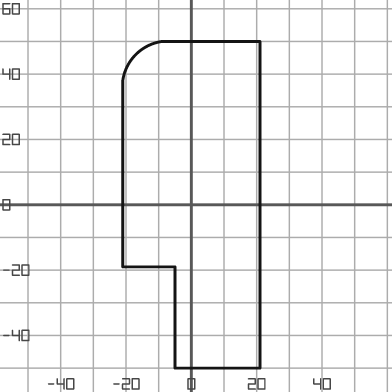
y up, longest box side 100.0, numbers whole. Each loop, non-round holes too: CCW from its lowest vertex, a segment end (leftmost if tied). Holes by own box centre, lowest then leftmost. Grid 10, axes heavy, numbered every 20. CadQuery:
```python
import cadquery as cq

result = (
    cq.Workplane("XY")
    .moveTo(-5.0, -50.0)
    .lineTo(21.0, -50.0)
    .lineTo(21.0, 50.0)
    .lineTo(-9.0, 50.0)
    .threePointArc((-17.0, 46.0), (-21.0, 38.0))
    .lineTo(-21.0, -19.0)
    .lineTo(-5.0, -19.0)
    .close()
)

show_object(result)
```